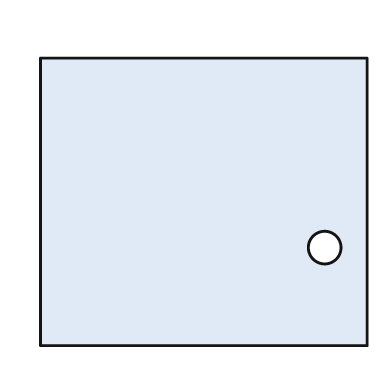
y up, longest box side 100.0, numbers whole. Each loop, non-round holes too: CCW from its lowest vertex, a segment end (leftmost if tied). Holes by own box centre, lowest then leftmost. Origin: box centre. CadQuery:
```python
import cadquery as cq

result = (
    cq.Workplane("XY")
    .moveTo(-50.0, -44.0)
    .lineTo(50.0, -44.0)
    .lineTo(50.0, 44.0)
    .lineTo(-50.0, 44.0)
    .close()
    .moveTo(37.0, -14.0)
    .circle(5.0)
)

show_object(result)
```